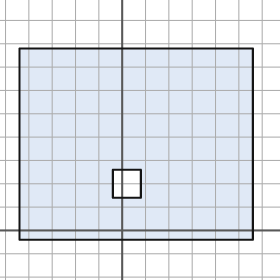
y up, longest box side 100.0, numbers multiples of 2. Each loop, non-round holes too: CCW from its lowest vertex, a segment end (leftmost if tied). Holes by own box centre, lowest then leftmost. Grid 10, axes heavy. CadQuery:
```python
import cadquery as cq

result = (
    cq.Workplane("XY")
    .moveTo(-44.0, -4.0)
    .lineTo(56.0, -4.0)
    .lineTo(56.0, 78.0)
    .lineTo(-44.0, 78.0)
    .close()
    .moveTo(-4.0, 14.0)
    .lineTo(8.0, 14.0)
    .lineTo(8.0, 26.0)
    .lineTo(-4.0, 26.0)
    .close()
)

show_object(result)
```